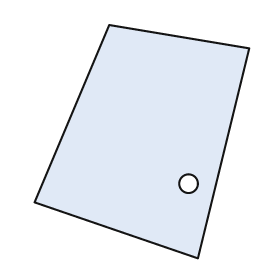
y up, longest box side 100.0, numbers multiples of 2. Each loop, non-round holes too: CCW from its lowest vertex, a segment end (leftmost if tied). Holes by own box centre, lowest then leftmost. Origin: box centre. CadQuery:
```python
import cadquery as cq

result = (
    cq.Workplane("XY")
    .moveTo(24.0, -50.0)
    .lineTo(46.0, 40.0)
    .lineTo(-14.0, 50.0)
    .lineTo(-46.0, -26.0)
    .close()
    .moveTo(20.0, -18.0)
    .circle(4.0)
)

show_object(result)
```